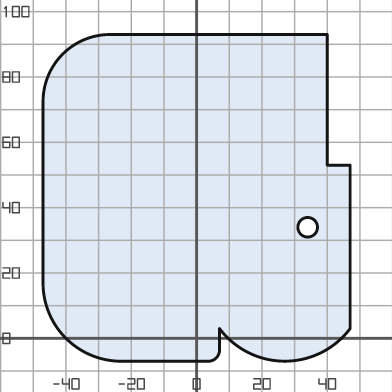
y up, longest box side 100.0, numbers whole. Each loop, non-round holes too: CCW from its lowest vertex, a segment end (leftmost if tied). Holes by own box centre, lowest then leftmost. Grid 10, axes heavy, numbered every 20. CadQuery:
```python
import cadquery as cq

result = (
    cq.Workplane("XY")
    .moveTo(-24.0, -7.0)
    .lineTo(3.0, -7.0)
    .threePointArc((6.0, -6.0), (7.0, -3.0))
    .lineTo(7.0, 3.0)
    .threePointArc((27.0, -7.0), (47.0, 3.0))
    .lineTo(47.0, 53.0)
    .lineTo(40.0, 53.0)
    .lineTo(40.0, 93.0)
    .lineTo(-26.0, 93.0)
    .threePointArc((-41.0, 87.0), (-47.0, 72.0))
    .lineTo(-47.0, 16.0)
    .threePointArc((-40.0, 0.0), (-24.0, -7.0))
    .close()
    .moveTo(34.0, 34.0)
    .circle(3.0)
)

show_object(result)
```